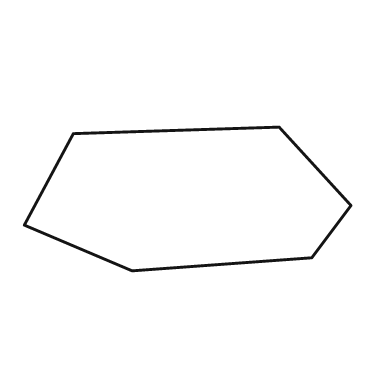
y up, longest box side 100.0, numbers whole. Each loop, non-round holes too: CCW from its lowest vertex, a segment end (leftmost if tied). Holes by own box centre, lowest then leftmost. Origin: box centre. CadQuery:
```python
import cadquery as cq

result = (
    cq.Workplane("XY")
    .moveTo(-17.0, -22.0)
    .lineTo(38.0, -18.0)
    .lineTo(50.0, -2.0)
    .lineTo(28.0, 22.0)
    .lineTo(-35.0, 20.0)
    .lineTo(-50.0, -8.0)
    .close()
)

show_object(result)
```